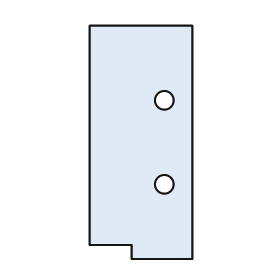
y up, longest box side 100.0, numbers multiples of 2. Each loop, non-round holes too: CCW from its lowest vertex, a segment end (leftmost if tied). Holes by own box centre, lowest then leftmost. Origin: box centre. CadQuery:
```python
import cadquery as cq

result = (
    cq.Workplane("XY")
    .moveTo(-4.0, -50.0)
    .lineTo(22.0, -50.0)
    .lineTo(22.0, 50.0)
    .lineTo(-22.0, 50.0)
    .lineTo(-22.0, -44.0)
    .lineTo(-4.0, -44.0)
    .close()
    .moveTo(10.0, -18.0)
    .circle(4.0)
    .moveTo(10.0, 18.0)
    .circle(4.0)
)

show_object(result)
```